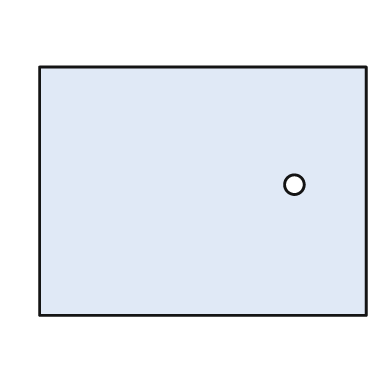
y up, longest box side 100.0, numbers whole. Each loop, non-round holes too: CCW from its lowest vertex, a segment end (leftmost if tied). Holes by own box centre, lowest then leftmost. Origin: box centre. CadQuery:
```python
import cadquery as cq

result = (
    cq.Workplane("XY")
    .moveTo(-50.0, -38.0)
    .lineTo(50.0, -38.0)
    .lineTo(50.0, 38.0)
    .lineTo(-50.0, 38.0)
    .close()
    .moveTo(28.0, 2.0)
    .circle(3.0)
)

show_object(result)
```